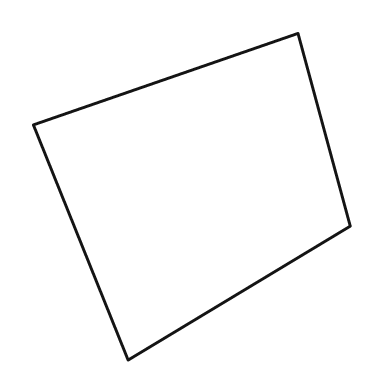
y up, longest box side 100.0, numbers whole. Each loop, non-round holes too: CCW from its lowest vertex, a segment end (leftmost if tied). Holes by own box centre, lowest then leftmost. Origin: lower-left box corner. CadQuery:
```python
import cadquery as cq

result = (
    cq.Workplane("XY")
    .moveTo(29.0, 0.0)
    .lineTo(97.0, 41.0)
    .lineTo(81.0, 100.0)
    .lineTo(0.0, 72.0)
    .close()
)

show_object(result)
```